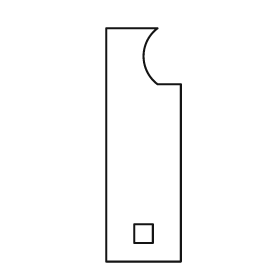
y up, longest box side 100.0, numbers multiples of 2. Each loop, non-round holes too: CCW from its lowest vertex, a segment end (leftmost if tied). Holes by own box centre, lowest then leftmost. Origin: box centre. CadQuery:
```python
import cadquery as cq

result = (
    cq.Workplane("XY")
    .moveTo(-16.0, -50.0)
    .lineTo(16.0, -50.0)
    .lineTo(16.0, 26.0)
    .lineTo(6.0, 26.0)
    .threePointArc((0.0, 38.0), (6.0, 50.0))
    .lineTo(-16.0, 50.0)
    .close()
    .moveTo(-4.0, -42.0)
    .lineTo(4.0, -42.0)
    .lineTo(4.0, -34.0)
    .lineTo(-4.0, -34.0)
    .close()
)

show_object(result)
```